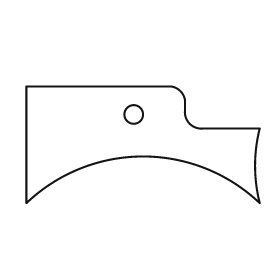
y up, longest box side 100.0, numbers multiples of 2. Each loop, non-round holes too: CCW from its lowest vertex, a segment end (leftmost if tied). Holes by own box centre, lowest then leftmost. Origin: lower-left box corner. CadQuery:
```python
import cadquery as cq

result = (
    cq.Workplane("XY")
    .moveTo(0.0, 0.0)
    .threePointArc((50.0, 20.0), (100.0, 0.0))
    .threePointArc((98.0, 16.0), (100.0, 32.0))
    .lineTo(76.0, 32.0)
    .threePointArc((70.0, 34.0), (68.0, 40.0))
    .lineTo(68.0, 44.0)
    .threePointArc((66.0, 48.0), (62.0, 50.0))
    .lineTo(0.0, 50.0)
    .close()
    .moveTo(46.0, 38.0)
    .circle(4.0)
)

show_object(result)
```